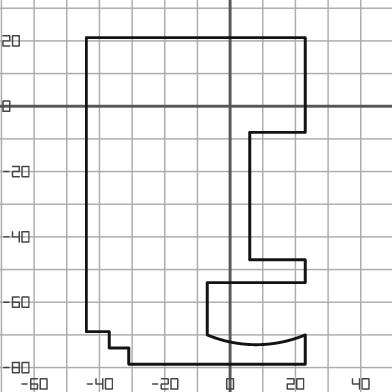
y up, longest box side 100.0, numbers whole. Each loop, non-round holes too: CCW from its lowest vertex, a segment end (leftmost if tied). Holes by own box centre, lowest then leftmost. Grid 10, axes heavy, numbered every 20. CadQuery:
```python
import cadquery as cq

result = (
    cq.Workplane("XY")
    .moveTo(-31.0, -79.0)
    .lineTo(23.0, -79.0)
    .lineTo(23.0, -70.0)
    .threePointArc((8.0, -73.0), (-7.0, -70.0))
    .lineTo(-7.0, -54.0)
    .lineTo(23.0, -54.0)
    .lineTo(23.0, -47.0)
    .lineTo(6.0, -47.0)
    .lineTo(6.0, -8.0)
    .lineTo(23.0, -8.0)
    .lineTo(23.0, 21.0)
    .lineTo(-44.0, 21.0)
    .lineTo(-44.0, -69.0)
    .lineTo(-37.0, -69.0)
    .lineTo(-37.0, -74.0)
    .lineTo(-31.0, -74.0)
    .close()
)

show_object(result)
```